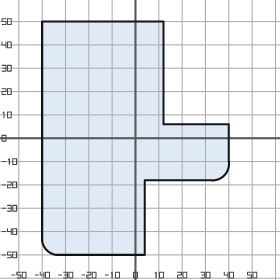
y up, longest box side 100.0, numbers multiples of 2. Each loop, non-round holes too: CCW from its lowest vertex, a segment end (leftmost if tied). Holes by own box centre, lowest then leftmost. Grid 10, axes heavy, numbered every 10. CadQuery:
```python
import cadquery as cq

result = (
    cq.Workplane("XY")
    .moveTo(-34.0, -50.0)
    .lineTo(4.0, -50.0)
    .lineTo(4.0, -18.0)
    .lineTo(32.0, -18.0)
    .threePointArc((38.0, -16.0), (40.0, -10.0))
    .lineTo(40.0, 6.0)
    .lineTo(12.0, 6.0)
    .lineTo(12.0, 50.0)
    .lineTo(-40.0, 50.0)
    .lineTo(-40.0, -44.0)
    .threePointArc((-38.0, -48.0), (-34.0, -50.0))
    .close()
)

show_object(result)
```